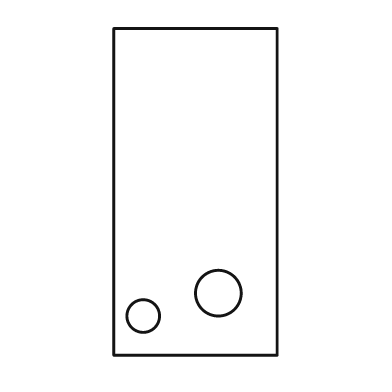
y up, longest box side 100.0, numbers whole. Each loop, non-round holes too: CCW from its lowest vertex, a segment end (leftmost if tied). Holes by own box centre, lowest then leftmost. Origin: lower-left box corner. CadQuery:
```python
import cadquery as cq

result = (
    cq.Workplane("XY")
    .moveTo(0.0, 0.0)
    .lineTo(50.0, 0.0)
    .lineTo(50.0, 100.0)
    .lineTo(0.0, 100.0)
    .close()
    .moveTo(9.0, 12.0)
    .circle(5.0)
    .moveTo(32.0, 19.0)
    .circle(7.0)
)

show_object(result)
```